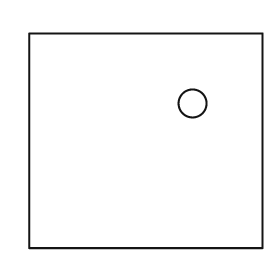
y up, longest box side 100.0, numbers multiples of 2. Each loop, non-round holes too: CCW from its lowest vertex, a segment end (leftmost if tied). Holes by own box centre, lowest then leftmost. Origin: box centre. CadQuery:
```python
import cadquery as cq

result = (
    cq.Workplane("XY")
    .moveTo(-50.0, -46.0)
    .lineTo(50.0, -46.0)
    .lineTo(50.0, 46.0)
    .lineTo(-50.0, 46.0)
    .close()
    .moveTo(20.0, 16.0)
    .circle(6.0)
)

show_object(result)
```